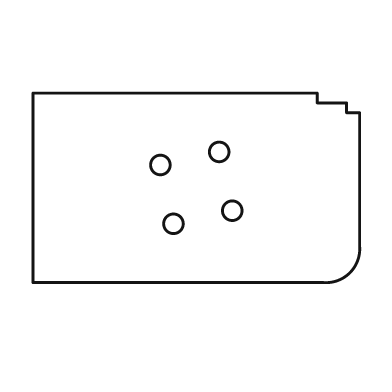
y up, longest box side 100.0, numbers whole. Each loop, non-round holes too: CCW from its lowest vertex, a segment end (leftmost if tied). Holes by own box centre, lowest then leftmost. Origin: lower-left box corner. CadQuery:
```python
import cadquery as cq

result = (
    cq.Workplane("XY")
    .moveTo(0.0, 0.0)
    .lineTo(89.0, 0.0)
    .threePointArc((97.0, 3.0), (100.0, 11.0))
    .lineTo(100.0, 52.0)
    .lineTo(96.0, 52.0)
    .lineTo(96.0, 55.0)
    .lineTo(87.0, 55.0)
    .lineTo(87.0, 58.0)
    .lineTo(0.0, 58.0)
    .close()
    .moveTo(43.0, 18.0)
    .circle(3.0)
    .moveTo(61.0, 22.0)
    .circle(3.0)
    .moveTo(39.0, 36.0)
    .circle(3.0)
    .moveTo(57.0, 40.0)
    .circle(3.0)
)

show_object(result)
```